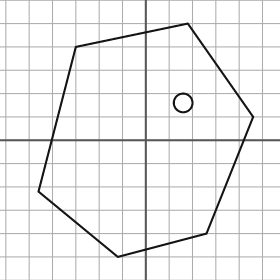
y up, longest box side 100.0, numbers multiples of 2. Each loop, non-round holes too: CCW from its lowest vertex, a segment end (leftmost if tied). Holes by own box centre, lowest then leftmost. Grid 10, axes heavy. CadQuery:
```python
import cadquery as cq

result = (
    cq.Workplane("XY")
    .moveTo(-12.0, -50.0)
    .lineTo(26.0, -40.0)
    .lineTo(46.0, 10.0)
    .lineTo(18.0, 50.0)
    .lineTo(-30.0, 40.0)
    .lineTo(-46.0, -22.0)
    .close()
    .moveTo(16.0, 16.0)
    .circle(4.0)
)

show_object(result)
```